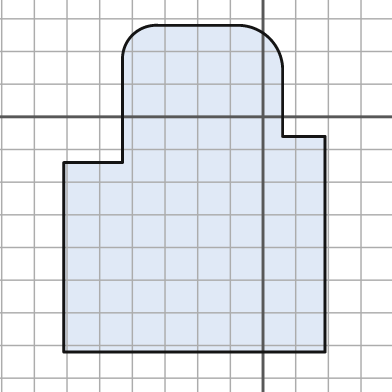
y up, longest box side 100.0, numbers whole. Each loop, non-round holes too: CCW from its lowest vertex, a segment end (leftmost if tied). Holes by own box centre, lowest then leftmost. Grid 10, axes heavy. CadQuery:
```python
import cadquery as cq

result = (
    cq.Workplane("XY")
    .moveTo(-61.0, -72.0)
    .lineTo(19.0, -72.0)
    .lineTo(19.0, -6.0)
    .lineTo(6.0, -6.0)
    .lineTo(6.0, 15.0)
    .threePointArc((2.0, 24.0), (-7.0, 28.0))
    .lineTo(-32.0, 28.0)
    .threePointArc((-40.0, 25.0), (-43.0, 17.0))
    .lineTo(-43.0, -14.0)
    .lineTo(-61.0, -14.0)
    .close()
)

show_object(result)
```